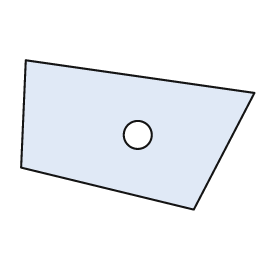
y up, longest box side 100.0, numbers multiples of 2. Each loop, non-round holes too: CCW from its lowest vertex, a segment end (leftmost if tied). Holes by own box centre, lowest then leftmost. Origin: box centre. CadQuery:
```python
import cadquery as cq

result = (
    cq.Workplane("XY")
    .moveTo(24.0, -32.0)
    .lineTo(50.0, 18.0)
    .lineTo(-48.0, 32.0)
    .lineTo(-50.0, -14.0)
    .close()
    .moveTo(0.0, 0.0)
    .circle(6.0)
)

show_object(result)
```